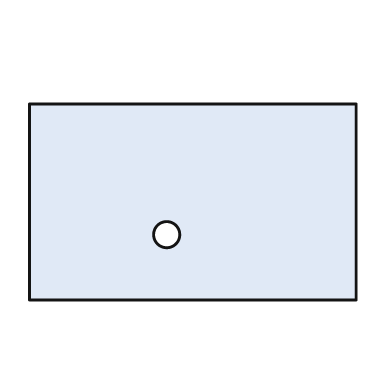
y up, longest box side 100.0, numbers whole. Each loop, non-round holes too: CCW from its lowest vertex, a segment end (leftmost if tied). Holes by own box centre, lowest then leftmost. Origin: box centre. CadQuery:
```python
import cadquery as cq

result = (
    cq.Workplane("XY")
    .moveTo(-50.0, -30.0)
    .lineTo(50.0, -30.0)
    .lineTo(50.0, 30.0)
    .lineTo(-50.0, 30.0)
    .close()
    .moveTo(-8.0, -10.0)
    .circle(4.0)
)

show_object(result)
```